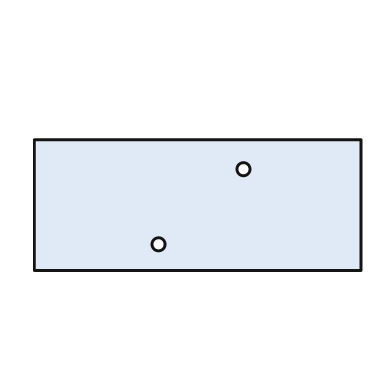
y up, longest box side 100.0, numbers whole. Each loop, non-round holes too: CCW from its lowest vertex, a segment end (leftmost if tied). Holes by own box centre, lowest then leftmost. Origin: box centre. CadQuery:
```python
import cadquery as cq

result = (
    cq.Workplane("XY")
    .moveTo(-50.0, -20.0)
    .lineTo(50.0, -20.0)
    .lineTo(50.0, 20.0)
    .lineTo(-50.0, 20.0)
    .close()
    .moveTo(-12.0, -12.0)
    .circle(2.0)
    .moveTo(14.0, 11.0)
    .circle(2.0)
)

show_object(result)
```